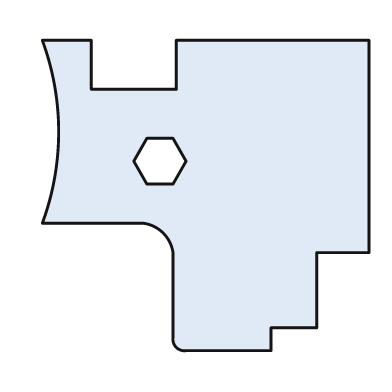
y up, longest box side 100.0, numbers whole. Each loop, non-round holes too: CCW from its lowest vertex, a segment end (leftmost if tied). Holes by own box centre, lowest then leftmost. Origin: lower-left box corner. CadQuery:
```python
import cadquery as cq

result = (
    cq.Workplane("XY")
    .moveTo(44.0, 0.0)
    .lineTo(70.0, 0.0)
    .lineTo(70.0, 7.0)
    .lineTo(84.0, 7.0)
    .lineTo(84.0, 30.0)
    .lineTo(100.0, 30.0)
    .lineTo(100.0, 95.0)
    .lineTo(41.0, 95.0)
    .lineTo(41.0, 80.0)
    .lineTo(15.0, 80.0)
    .lineTo(15.0, 95.0)
    .lineTo(0.0, 95.0)
    .threePointArc((5.0, 67.0), (0.0, 39.0))
    .lineTo(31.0, 39.0)
    .threePointArc((37.0, 36.0), (40.0, 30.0))
    .lineTo(40.0, 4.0)
    .threePointArc((41.0, 1.0), (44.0, 0.0))
    .close()
    .moveTo(32.0, 51.0)
    .lineTo(40.0, 51.0)
    .lineTo(44.0, 58.0)
    .lineTo(40.0, 65.0)
    .lineTo(32.0, 65.0)
    .lineTo(28.0, 58.0)
    .close()
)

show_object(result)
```